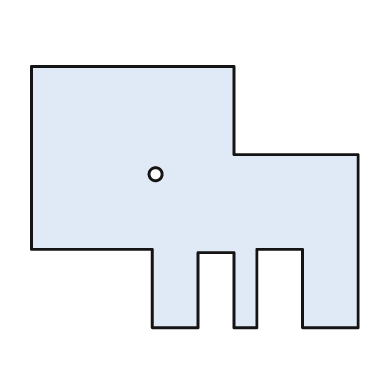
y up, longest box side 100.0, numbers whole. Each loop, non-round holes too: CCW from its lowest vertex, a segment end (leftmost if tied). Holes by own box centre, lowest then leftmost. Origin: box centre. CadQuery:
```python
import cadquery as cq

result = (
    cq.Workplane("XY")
    .moveTo(-13.0, -40.0)
    .lineTo(1.0, -40.0)
    .lineTo(1.0, -17.0)
    .lineTo(12.0, -17.0)
    .lineTo(12.0, -40.0)
    .lineTo(19.0, -40.0)
    .lineTo(19.0, -16.0)
    .lineTo(33.0, -16.0)
    .lineTo(33.0, -40.0)
    .lineTo(50.0, -40.0)
    .lineTo(50.0, 13.0)
    .lineTo(12.0, 13.0)
    .lineTo(12.0, 40.0)
    .lineTo(-50.0, 40.0)
    .lineTo(-50.0, -16.0)
    .lineTo(-13.0, -16.0)
    .close()
    .moveTo(-12.0, 7.0)
    .circle(2.0)
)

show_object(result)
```